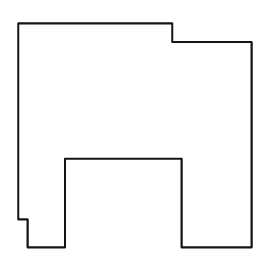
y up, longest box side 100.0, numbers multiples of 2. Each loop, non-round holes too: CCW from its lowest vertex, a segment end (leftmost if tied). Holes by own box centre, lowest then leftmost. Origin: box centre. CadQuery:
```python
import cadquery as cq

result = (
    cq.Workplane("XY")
    .moveTo(-46.0, -48.0)
    .lineTo(-30.0, -48.0)
    .lineTo(-30.0, -10.0)
    .lineTo(20.0, -10.0)
    .lineTo(20.0, -48.0)
    .lineTo(50.0, -48.0)
    .lineTo(50.0, 40.0)
    .lineTo(16.0, 40.0)
    .lineTo(16.0, 48.0)
    .lineTo(-50.0, 48.0)
    .lineTo(-50.0, -36.0)
    .lineTo(-46.0, -36.0)
    .close()
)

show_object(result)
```